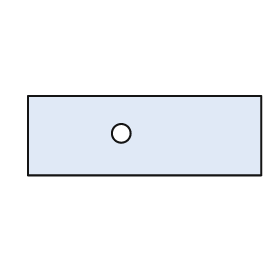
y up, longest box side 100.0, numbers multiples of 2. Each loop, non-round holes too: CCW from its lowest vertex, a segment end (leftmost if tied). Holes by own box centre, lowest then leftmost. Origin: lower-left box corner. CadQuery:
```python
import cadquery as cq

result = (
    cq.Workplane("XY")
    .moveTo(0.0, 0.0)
    .lineTo(100.0, 0.0)
    .lineTo(100.0, 34.0)
    .lineTo(0.0, 34.0)
    .close()
    .moveTo(40.0, 18.0)
    .circle(4.0)
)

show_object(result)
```